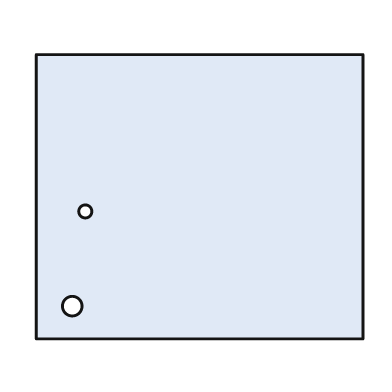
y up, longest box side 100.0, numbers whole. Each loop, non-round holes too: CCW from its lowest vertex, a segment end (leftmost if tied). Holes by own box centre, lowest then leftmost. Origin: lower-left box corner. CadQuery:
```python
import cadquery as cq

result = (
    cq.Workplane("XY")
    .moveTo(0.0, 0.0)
    .lineTo(100.0, 0.0)
    .lineTo(100.0, 87.0)
    .lineTo(0.0, 87.0)
    .close()
    .moveTo(11.0, 10.0)
    .circle(3.0)
    .moveTo(15.0, 39.0)
    .circle(2.0)
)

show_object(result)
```